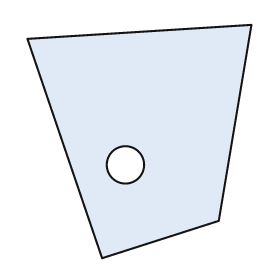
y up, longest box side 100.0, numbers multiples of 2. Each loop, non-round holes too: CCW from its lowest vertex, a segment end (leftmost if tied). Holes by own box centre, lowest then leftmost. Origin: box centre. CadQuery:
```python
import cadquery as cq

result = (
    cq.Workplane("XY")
    .moveTo(-16.0, -50.0)
    .lineTo(34.0, -34.0)
    .lineTo(48.0, 50.0)
    .lineTo(-48.0, 44.0)
    .close()
    .moveTo(-6.0, -10.0)
    .circle(8.0)
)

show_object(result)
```